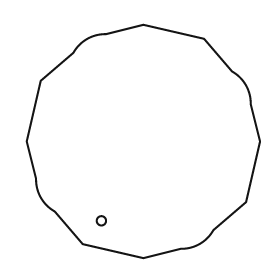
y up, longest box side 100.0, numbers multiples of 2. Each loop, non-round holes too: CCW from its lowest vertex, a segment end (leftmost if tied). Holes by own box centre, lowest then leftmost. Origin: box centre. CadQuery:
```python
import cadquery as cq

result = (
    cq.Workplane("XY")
    .moveTo(0.0, -50.0)
    .lineTo(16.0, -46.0)
    .threePointArc((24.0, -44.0), (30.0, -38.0))
    .lineTo(44.0, -26.0)
    .lineTo(50.0, 0.0)
    .lineTo(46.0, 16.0)
    .threePointArc((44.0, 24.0), (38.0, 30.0))
    .lineTo(26.0, 44.0)
    .lineTo(0.0, 50.0)
    .lineTo(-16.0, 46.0)
    .threePointArc((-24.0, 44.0), (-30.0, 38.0))
    .lineTo(-44.0, 26.0)
    .lineTo(-50.0, 0.0)
    .lineTo(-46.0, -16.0)
    .threePointArc((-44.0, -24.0), (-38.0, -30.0))
    .lineTo(-26.0, -44.0)
    .close()
    .moveTo(-18.0, -34.0)
    .circle(2.0)
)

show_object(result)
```